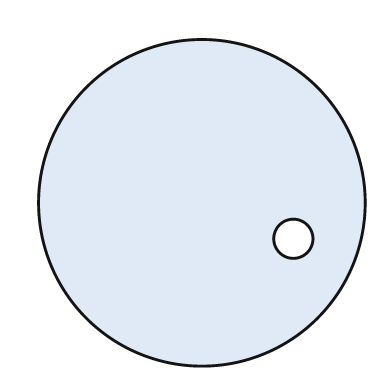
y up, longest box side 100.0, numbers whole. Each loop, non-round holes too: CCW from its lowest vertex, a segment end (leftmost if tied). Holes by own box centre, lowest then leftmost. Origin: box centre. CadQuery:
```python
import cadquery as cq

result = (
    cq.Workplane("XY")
    .moveTo(0.0, 0.0)
    .circle(50.0)
    .moveTo(28.0, -11.0)
    .circle(6.0)
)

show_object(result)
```